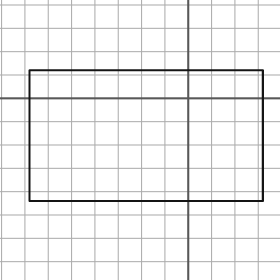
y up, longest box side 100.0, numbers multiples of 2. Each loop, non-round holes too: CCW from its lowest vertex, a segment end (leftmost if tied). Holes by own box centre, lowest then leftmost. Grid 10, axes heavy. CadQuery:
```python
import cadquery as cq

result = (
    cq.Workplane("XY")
    .moveTo(-68.0, -44.0)
    .lineTo(32.0, -44.0)
    .lineTo(32.0, 12.0)
    .lineTo(-68.0, 12.0)
    .close()
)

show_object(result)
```